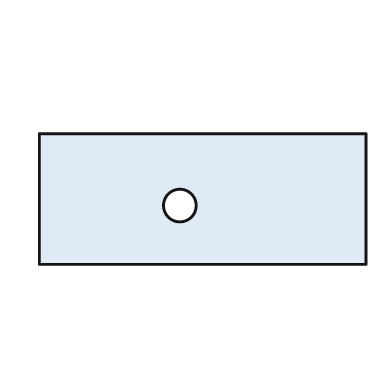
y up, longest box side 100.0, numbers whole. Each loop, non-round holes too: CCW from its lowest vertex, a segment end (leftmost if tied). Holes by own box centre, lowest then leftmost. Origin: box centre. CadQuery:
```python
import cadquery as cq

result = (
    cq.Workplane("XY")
    .moveTo(-50.0, -20.0)
    .lineTo(50.0, -20.0)
    .lineTo(50.0, 20.0)
    .lineTo(-50.0, 20.0)
    .close()
    .moveTo(-7.0, -2.0)
    .circle(5.0)
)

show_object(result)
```